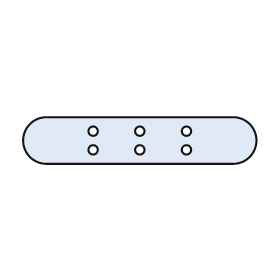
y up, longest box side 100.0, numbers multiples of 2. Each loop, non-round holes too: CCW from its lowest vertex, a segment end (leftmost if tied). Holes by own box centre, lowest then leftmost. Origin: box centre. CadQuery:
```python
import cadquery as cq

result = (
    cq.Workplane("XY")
    .moveTo(-40.0, -10.0)
    .lineTo(40.0, -10.0)
    .threePointArc((50.0, 0.0), (40.0, 10.0))
    .lineTo(-40.0, 10.0)
    .threePointArc((-50.0, 0.0), (-40.0, -10.0))
    .close()
    .moveTo(-20.0, -4.0)
    .circle(2.0)
    .moveTo(0.0, -4.0)
    .circle(2.0)
    .moveTo(20.0, -4.0)
    .circle(2.0)
    .moveTo(-20.0, 4.0)
    .circle(2.0)
    .moveTo(0.0, 4.0)
    .circle(2.0)
    .moveTo(20.0, 4.0)
    .circle(2.0)
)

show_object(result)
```